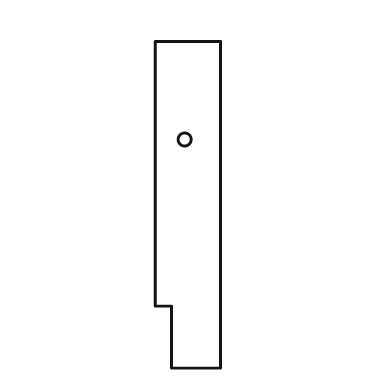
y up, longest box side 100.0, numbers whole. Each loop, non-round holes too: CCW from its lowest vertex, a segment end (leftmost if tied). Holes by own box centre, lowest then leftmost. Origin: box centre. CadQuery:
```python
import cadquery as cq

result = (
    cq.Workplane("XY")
    .moveTo(-5.0, -50.0)
    .lineTo(10.0, -50.0)
    .lineTo(10.0, 50.0)
    .lineTo(-10.0, 50.0)
    .lineTo(-10.0, -31.0)
    .lineTo(-5.0, -31.0)
    .close()
    .moveTo(-1.0, 20.0)
    .circle(2.0)
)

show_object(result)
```